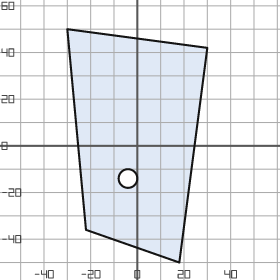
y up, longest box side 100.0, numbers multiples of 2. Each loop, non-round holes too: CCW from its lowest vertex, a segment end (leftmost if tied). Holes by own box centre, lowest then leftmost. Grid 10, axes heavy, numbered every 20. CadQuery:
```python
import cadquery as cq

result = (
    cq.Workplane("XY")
    .moveTo(18.0, -50.0)
    .lineTo(30.0, 42.0)
    .lineTo(-30.0, 50.0)
    .lineTo(-22.0, -36.0)
    .close()
    .moveTo(-4.0, -14.0)
    .circle(4.0)
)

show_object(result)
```